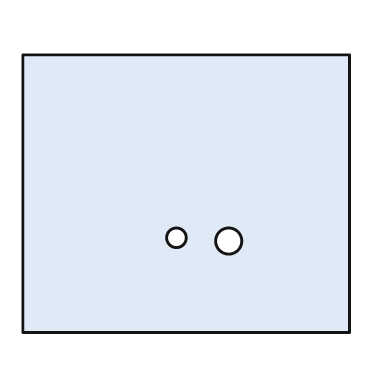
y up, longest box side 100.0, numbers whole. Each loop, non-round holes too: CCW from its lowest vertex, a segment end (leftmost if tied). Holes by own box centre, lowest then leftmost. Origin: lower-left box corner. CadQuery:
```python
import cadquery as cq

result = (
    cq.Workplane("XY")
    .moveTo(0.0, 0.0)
    .lineTo(100.0, 0.0)
    .lineTo(100.0, 85.0)
    .lineTo(0.0, 85.0)
    .close()
    .moveTo(63.0, 28.0)
    .circle(4.0)
    .moveTo(47.0, 29.0)
    .circle(3.0)
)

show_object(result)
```